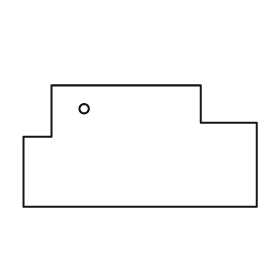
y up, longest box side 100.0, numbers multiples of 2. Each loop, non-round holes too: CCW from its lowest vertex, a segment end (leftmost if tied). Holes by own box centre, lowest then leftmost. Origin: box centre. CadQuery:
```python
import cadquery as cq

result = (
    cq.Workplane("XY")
    .moveTo(-50.0, -26.0)
    .lineTo(50.0, -26.0)
    .lineTo(50.0, 10.0)
    .lineTo(26.0, 10.0)
    .lineTo(26.0, 26.0)
    .lineTo(-38.0, 26.0)
    .lineTo(-38.0, 4.0)
    .lineTo(-50.0, 4.0)
    .close()
    .moveTo(-24.0, 16.0)
    .circle(2.0)
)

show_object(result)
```